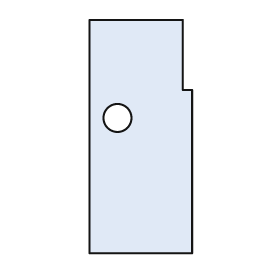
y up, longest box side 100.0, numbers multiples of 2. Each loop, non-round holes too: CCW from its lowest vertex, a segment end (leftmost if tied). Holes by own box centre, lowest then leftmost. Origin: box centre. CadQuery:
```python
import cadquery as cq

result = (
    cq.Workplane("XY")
    .moveTo(-22.0, -50.0)
    .lineTo(22.0, -50.0)
    .lineTo(22.0, 20.0)
    .lineTo(18.0, 20.0)
    .lineTo(18.0, 50.0)
    .lineTo(-22.0, 50.0)
    .close()
    .moveTo(-10.0, 8.0)
    .circle(6.0)
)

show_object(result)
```